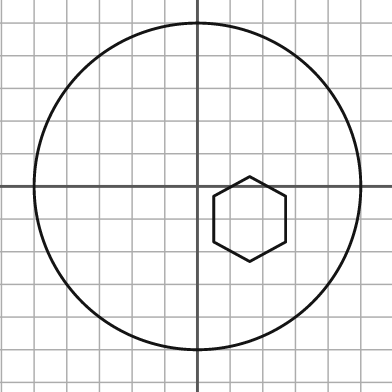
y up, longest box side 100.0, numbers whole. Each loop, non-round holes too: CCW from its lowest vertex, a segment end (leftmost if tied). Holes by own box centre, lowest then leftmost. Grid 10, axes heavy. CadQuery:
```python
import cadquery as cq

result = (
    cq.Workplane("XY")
    .moveTo(0.0, 0.0)
    .circle(50.0)
    .moveTo(16.0, -23.0)
    .lineTo(27.0, -17.0)
    .lineTo(27.0, -3.0)
    .lineTo(16.0, 3.0)
    .lineTo(5.0, -3.0)
    .lineTo(5.0, -17.0)
    .close()
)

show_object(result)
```